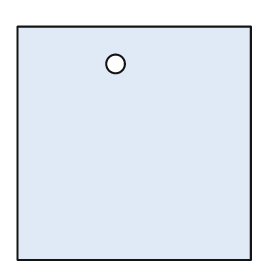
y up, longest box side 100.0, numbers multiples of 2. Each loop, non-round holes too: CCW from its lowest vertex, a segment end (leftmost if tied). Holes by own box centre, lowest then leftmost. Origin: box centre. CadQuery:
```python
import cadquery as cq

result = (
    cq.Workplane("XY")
    .moveTo(-50.0, -50.0)
    .lineTo(50.0, -50.0)
    .lineTo(50.0, 50.0)
    .lineTo(-50.0, 50.0)
    .close()
    .moveTo(-8.0, 34.0)
    .circle(4.0)
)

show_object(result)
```